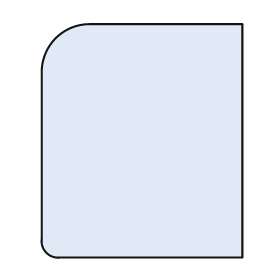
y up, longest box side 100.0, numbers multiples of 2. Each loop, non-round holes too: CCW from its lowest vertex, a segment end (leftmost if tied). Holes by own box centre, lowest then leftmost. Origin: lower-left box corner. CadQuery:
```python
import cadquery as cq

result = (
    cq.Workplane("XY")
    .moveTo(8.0, 0.0)
    .lineTo(86.0, 0.0)
    .lineTo(86.0, 100.0)
    .lineTo(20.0, 100.0)
    .threePointArc((6.0, 94.0), (0.0, 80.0))
    .lineTo(0.0, 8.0)
    .threePointArc((2.0, 2.0), (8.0, 0.0))
    .close()
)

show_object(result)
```